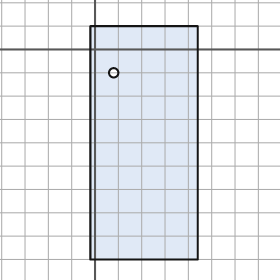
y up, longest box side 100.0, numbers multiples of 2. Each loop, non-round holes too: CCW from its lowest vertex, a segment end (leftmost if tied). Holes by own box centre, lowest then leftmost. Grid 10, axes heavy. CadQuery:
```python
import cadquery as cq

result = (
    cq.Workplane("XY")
    .moveTo(-2.0, -90.0)
    .lineTo(44.0, -90.0)
    .lineTo(44.0, 10.0)
    .lineTo(-2.0, 10.0)
    .close()
    .moveTo(8.0, -10.0)
    .circle(2.0)
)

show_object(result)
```